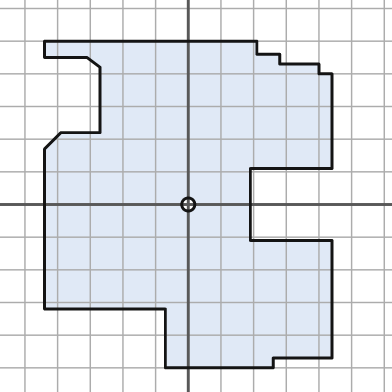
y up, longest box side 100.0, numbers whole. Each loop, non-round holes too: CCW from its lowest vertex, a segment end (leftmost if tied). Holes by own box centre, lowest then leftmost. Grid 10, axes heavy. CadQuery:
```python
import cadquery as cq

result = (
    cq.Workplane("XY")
    .moveTo(-7.0, -50.0)
    .lineTo(26.0, -50.0)
    .lineTo(26.0, -47.0)
    .lineTo(44.0, -47.0)
    .lineTo(44.0, -11.0)
    .lineTo(19.0, -11.0)
    .lineTo(19.0, 11.0)
    .lineTo(44.0, 11.0)
    .lineTo(44.0, 40.0)
    .lineTo(40.0, 40.0)
    .lineTo(40.0, 43.0)
    .lineTo(28.0, 43.0)
    .lineTo(28.0, 46.0)
    .lineTo(21.0, 46.0)
    .lineTo(21.0, 50.0)
    .lineTo(-44.0, 50.0)
    .lineTo(-44.0, 45.0)
    .lineTo(-31.0, 45.0)
    .lineTo(-27.0, 42.0)
    .lineTo(-27.0, 22.0)
    .lineTo(-39.0, 22.0)
    .lineTo(-44.0, 17.0)
    .lineTo(-44.0, -32.0)
    .lineTo(-7.0, -32.0)
    .close()
    .moveTo(0.0, 0.0)
    .circle(2.0)
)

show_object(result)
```